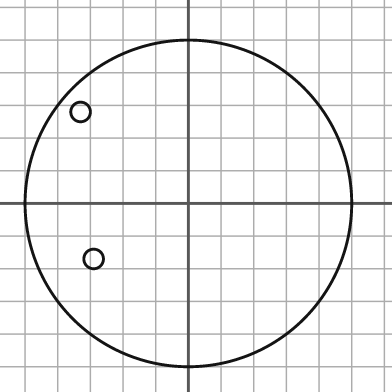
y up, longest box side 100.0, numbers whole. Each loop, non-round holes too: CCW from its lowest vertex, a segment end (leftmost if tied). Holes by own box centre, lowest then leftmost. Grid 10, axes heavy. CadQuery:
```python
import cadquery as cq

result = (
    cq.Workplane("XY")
    .moveTo(0.0, 0.0)
    .circle(50.0)
    .moveTo(-29.0, -17.0)
    .circle(3.0)
    .moveTo(-33.0, 28.0)
    .circle(3.0)
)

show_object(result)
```